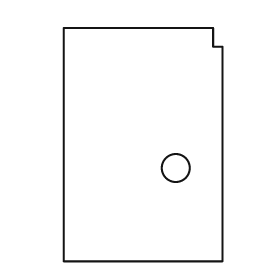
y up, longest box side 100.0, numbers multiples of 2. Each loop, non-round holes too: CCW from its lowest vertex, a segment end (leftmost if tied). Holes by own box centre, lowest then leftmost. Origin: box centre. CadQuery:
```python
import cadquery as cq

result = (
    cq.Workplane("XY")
    .moveTo(-34.0, -50.0)
    .lineTo(34.0, -50.0)
    .lineTo(34.0, 42.0)
    .lineTo(30.0, 42.0)
    .lineTo(30.0, 50.0)
    .lineTo(-34.0, 50.0)
    .close()
    .moveTo(14.0, -10.0)
    .circle(6.0)
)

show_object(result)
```